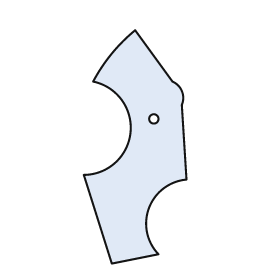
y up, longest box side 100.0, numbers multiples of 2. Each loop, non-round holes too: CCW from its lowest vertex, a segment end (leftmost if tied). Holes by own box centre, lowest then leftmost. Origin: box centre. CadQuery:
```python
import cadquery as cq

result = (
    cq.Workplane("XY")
    .moveTo(-10.0, -50.0)
    .lineTo(10.0, -46.0)
    .threePointArc((6.0, -26.0), (22.0, -14.0))
    .lineTo(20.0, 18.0)
    .threePointArc((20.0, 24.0), (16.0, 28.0))
    .lineTo(0.0, 50.0)
    .threePointArc((-10.0, 40.0), (-18.0, 28.0))
    .threePointArc((-2.0, 6.0), (-22.0, -12.0))
    .close()
    .moveTo(8.0, 12.0)
    .circle(2.0)
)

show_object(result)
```